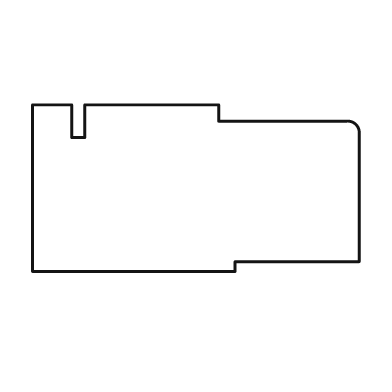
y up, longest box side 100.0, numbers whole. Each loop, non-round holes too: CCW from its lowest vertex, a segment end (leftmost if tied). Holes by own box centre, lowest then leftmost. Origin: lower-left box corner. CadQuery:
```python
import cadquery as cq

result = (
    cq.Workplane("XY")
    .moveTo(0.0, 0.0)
    .lineTo(62.0, 0.0)
    .lineTo(62.0, 3.0)
    .lineTo(100.0, 3.0)
    .lineTo(100.0, 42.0)
    .threePointArc((99.0, 45.0), (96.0, 46.0))
    .lineTo(57.0, 46.0)
    .lineTo(57.0, 51.0)
    .lineTo(16.0, 51.0)
    .lineTo(16.0, 41.0)
    .lineTo(12.0, 41.0)
    .lineTo(12.0, 51.0)
    .lineTo(0.0, 51.0)
    .close()
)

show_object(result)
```